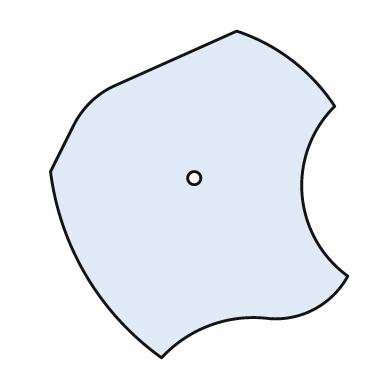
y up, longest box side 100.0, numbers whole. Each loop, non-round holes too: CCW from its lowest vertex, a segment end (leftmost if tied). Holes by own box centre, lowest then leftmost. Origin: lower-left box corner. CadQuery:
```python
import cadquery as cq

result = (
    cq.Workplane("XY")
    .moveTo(34.0, 0.0)
    .threePointArc((49.0, 10.0), (67.0, 12.0))
    .threePointArc((81.0, 15.0), (91.0, 25.0))
    .threePointArc((77.0, 50.0), (87.0, 77.0))
    .threePointArc((74.0, 91.0), (57.0, 100.0))
    .lineTo(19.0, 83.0)
    .threePointArc((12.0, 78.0), (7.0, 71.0))
    .lineTo(0.0, 57.0)
    .threePointArc((11.0, 25.0), (34.0, 0.0))
    .close()
    .moveTo(44.0, 55.0)
    .circle(2.0)
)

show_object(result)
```